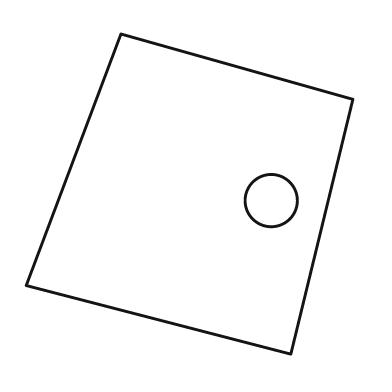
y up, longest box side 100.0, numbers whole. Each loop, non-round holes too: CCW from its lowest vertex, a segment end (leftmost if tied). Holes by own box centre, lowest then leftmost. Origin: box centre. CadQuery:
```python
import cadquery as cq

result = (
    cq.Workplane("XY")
    .moveTo(31.0, -49.0)
    .lineTo(50.0, 29.0)
    .lineTo(-21.0, 49.0)
    .lineTo(-50.0, -28.0)
    .close()
    .moveTo(25.0, -2.0)
    .circle(8.0)
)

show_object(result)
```